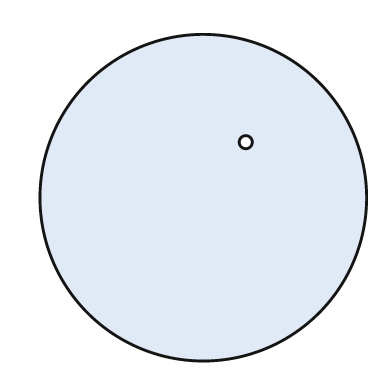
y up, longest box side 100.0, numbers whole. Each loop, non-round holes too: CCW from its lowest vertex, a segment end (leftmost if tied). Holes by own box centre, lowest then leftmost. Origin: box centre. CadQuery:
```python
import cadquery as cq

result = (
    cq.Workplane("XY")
    .moveTo(0.0, 0.0)
    .circle(50.0)
    .moveTo(13.0, 17.0)
    .circle(2.0)
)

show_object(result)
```